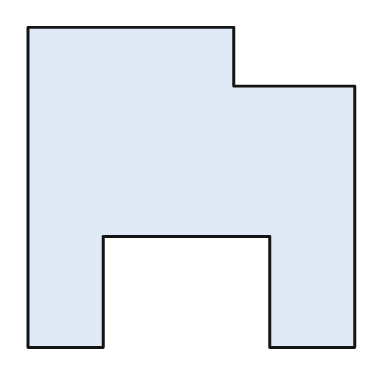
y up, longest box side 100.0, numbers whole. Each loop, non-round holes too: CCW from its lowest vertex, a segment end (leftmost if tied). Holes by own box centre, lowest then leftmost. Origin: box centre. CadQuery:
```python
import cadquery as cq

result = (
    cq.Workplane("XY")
    .moveTo(-50.0, -49.0)
    .lineTo(-27.0, -49.0)
    .lineTo(-27.0, -15.0)
    .lineTo(24.0, -15.0)
    .lineTo(24.0, -49.0)
    .lineTo(50.0, -49.0)
    .lineTo(50.0, 31.0)
    .lineTo(13.0, 31.0)
    .lineTo(13.0, 49.0)
    .lineTo(-50.0, 49.0)
    .close()
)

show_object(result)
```